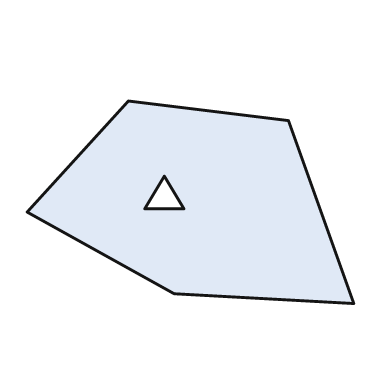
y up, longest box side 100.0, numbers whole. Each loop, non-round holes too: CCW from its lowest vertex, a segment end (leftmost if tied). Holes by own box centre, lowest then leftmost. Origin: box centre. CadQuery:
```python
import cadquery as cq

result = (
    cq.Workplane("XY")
    .moveTo(50.0, -31.0)
    .lineTo(30.0, 25.0)
    .lineTo(-19.0, 31.0)
    .lineTo(-50.0, -3.0)
    .lineTo(-5.0, -28.0)
    .close()
    .moveTo(-14.0, -2.0)
    .lineTo(-2.0, -2.0)
    .lineTo(-8.0, 8.0)
    .close()
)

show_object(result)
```